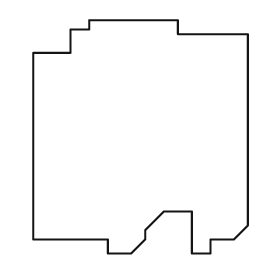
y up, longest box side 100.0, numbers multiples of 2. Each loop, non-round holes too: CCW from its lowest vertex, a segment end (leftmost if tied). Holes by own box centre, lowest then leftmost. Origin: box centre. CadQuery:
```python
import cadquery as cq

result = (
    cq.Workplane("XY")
    .moveTo(-14.0, -50.0)
    .lineTo(-4.0, -50.0)
    .lineTo(2.0, -44.0)
    .lineTo(2.0, -40.0)
    .lineTo(10.0, -32.0)
    .lineTo(22.0, -32.0)
    .lineTo(22.0, -50.0)
    .lineTo(30.0, -50.0)
    .lineTo(30.0, -44.0)
    .lineTo(40.0, -44.0)
    .lineTo(46.0, -38.0)
    .lineTo(46.0, 44.0)
    .lineTo(16.0, 44.0)
    .lineTo(16.0, 50.0)
    .lineTo(-22.0, 50.0)
    .lineTo(-22.0, 46.0)
    .lineTo(-30.0, 46.0)
    .lineTo(-30.0, 36.0)
    .lineTo(-46.0, 36.0)
    .lineTo(-46.0, -44.0)
    .lineTo(-14.0, -44.0)
    .close()
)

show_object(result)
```